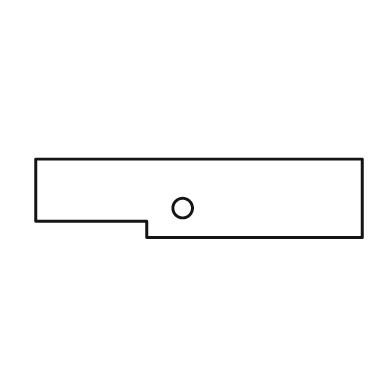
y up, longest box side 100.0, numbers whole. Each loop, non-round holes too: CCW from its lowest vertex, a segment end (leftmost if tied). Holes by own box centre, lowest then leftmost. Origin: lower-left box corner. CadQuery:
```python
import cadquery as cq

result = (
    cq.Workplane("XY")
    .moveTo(34.0, 0.0)
    .lineTo(100.0, 0.0)
    .lineTo(100.0, 24.0)
    .lineTo(0.0, 24.0)
    .lineTo(0.0, 5.0)
    .lineTo(34.0, 5.0)
    .close()
    .moveTo(45.0, 9.0)
    .circle(3.0)
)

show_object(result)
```